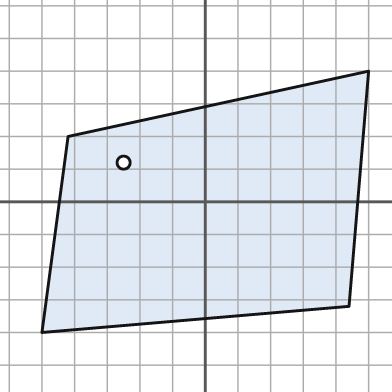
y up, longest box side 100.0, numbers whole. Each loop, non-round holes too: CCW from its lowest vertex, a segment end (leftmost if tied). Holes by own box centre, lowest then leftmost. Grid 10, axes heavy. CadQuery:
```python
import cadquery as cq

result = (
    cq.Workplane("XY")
    .moveTo(-50.0, -40.0)
    .lineTo(44.0, -32.0)
    .lineTo(50.0, 40.0)
    .lineTo(-42.0, 20.0)
    .close()
    .moveTo(-25.0, 12.0)
    .circle(2.0)
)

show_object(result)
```